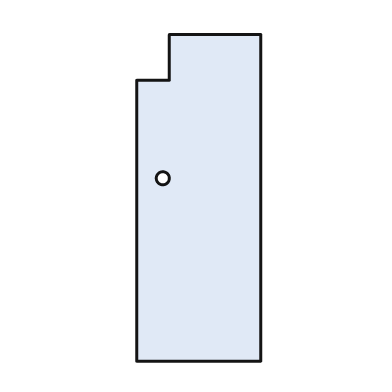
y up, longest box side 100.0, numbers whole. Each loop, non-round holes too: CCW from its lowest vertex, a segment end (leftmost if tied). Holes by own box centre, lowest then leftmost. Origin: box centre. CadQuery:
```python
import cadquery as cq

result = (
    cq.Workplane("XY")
    .moveTo(-19.0, -50.0)
    .lineTo(19.0, -50.0)
    .lineTo(19.0, 50.0)
    .lineTo(-9.0, 50.0)
    .lineTo(-9.0, 36.0)
    .lineTo(-19.0, 36.0)
    .close()
    .moveTo(-11.0, 6.0)
    .circle(2.0)
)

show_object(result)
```